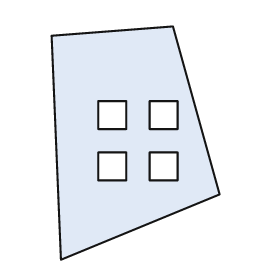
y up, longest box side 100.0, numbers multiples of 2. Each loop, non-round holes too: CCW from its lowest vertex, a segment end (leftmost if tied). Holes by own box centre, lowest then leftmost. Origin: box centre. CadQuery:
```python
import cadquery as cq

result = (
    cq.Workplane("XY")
    .moveTo(-32.0, -50.0)
    .lineTo(36.0, -22.0)
    .lineTo(16.0, 50.0)
    .lineTo(-36.0, 46.0)
    .close()
    .moveTo(-16.0, -16.0)
    .lineTo(-4.0, -16.0)
    .lineTo(-4.0, -4.0)
    .lineTo(-16.0, -4.0)
    .close()
    .moveTo(6.0, -16.0)
    .lineTo(18.0, -16.0)
    .lineTo(18.0, -4.0)
    .lineTo(6.0, -4.0)
    .close()
    .moveTo(-16.0, 6.0)
    .lineTo(-4.0, 6.0)
    .lineTo(-4.0, 18.0)
    .lineTo(-16.0, 18.0)
    .close()
    .moveTo(6.0, 6.0)
    .lineTo(18.0, 6.0)
    .lineTo(18.0, 18.0)
    .lineTo(6.0, 18.0)
    .close()
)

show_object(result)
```